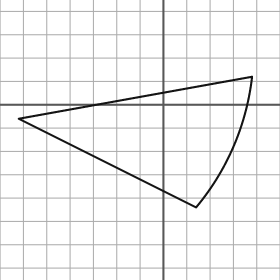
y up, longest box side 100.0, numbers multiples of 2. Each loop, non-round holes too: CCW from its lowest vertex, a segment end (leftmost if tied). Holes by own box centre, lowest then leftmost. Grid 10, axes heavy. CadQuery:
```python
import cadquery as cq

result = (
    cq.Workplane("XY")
    .moveTo(14.0, -44.0)
    .threePointArc((30.0, -18.0), (38.0, 12.0))
    .lineTo(-62.0, -6.0)
    .close()
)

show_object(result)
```